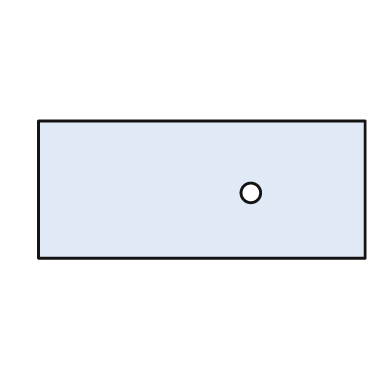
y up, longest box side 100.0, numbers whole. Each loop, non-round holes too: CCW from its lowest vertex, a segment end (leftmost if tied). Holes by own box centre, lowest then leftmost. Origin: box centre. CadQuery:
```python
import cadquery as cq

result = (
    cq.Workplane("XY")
    .moveTo(-50.0, -21.0)
    .lineTo(50.0, -21.0)
    .lineTo(50.0, 21.0)
    .lineTo(-50.0, 21.0)
    .close()
    .moveTo(15.0, -1.0)
    .circle(3.0)
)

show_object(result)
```